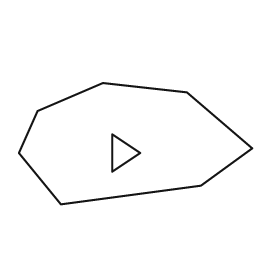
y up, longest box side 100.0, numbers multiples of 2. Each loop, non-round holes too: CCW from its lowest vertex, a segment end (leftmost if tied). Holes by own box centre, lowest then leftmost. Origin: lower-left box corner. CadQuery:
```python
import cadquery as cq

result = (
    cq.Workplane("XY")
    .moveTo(18.0, 0.0)
    .lineTo(78.0, 8.0)
    .lineTo(100.0, 24.0)
    .lineTo(72.0, 48.0)
    .lineTo(36.0, 52.0)
    .lineTo(8.0, 40.0)
    .lineTo(0.0, 22.0)
    .close()
    .moveTo(40.0, 14.0)
    .lineTo(52.0, 22.0)
    .lineTo(40.0, 30.0)
    .close()
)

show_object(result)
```